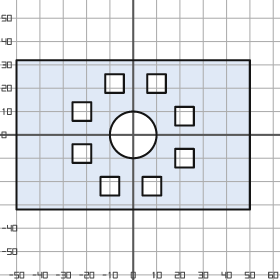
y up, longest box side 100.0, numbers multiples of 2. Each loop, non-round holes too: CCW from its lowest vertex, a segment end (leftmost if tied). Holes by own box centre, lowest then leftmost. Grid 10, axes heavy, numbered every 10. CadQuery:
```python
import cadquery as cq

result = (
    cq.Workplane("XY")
    .moveTo(-50.0, -32.0)
    .lineTo(50.0, -32.0)
    .lineTo(50.0, 32.0)
    .lineTo(-50.0, 32.0)
    .close()
    .moveTo(-14.0, -26.0)
    .lineTo(-6.0, -26.0)
    .lineTo(-6.0, -18.0)
    .lineTo(-14.0, -18.0)
    .close()
    .moveTo(4.0, -26.0)
    .lineTo(12.0, -26.0)
    .lineTo(12.0, -18.0)
    .lineTo(4.0, -18.0)
    .close()
    .moveTo(18.0, -14.0)
    .lineTo(26.0, -14.0)
    .lineTo(26.0, -6.0)
    .lineTo(18.0, -6.0)
    .close()
    .moveTo(-26.0, -12.0)
    .lineTo(-18.0, -12.0)
    .lineTo(-18.0, -4.0)
    .lineTo(-26.0, -4.0)
    .close()
    .moveTo(0.0, 0.0)
    .circle(10.0)
    .moveTo(18.0, 4.0)
    .lineTo(26.0, 4.0)
    .lineTo(26.0, 12.0)
    .lineTo(18.0, 12.0)
    .close()
    .moveTo(-26.0, 6.0)
    .lineTo(-18.0, 6.0)
    .lineTo(-18.0, 14.0)
    .lineTo(-26.0, 14.0)
    .close()
    .moveTo(-12.0, 18.0)
    .lineTo(-4.0, 18.0)
    .lineTo(-4.0, 26.0)
    .lineTo(-12.0, 26.0)
    .close()
    .moveTo(6.0, 18.0)
    .lineTo(14.0, 18.0)
    .lineTo(14.0, 26.0)
    .lineTo(6.0, 26.0)
    .close()
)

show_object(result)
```